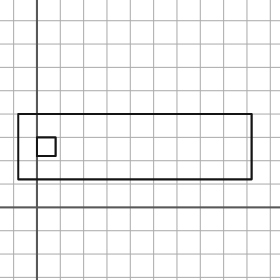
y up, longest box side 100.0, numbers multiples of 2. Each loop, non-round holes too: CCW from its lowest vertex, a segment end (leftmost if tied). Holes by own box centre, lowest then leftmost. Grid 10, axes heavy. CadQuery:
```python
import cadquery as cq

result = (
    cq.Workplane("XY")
    .moveTo(-8.0, 12.0)
    .lineTo(92.0, 12.0)
    .lineTo(92.0, 40.0)
    .lineTo(-8.0, 40.0)
    .close()
    .moveTo(0.0, 22.0)
    .lineTo(8.0, 22.0)
    .lineTo(8.0, 30.0)
    .lineTo(0.0, 30.0)
    .close()
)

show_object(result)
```